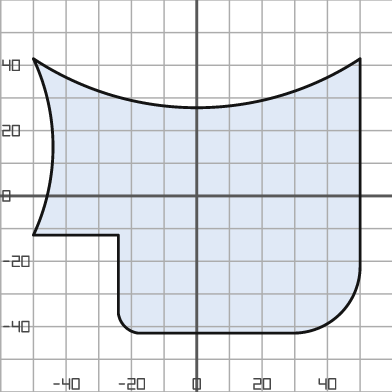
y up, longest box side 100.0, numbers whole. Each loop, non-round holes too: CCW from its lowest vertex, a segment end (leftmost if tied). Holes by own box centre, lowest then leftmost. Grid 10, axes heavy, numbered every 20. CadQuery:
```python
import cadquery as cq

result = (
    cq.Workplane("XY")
    .moveTo(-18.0, -42.0)
    .lineTo(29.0, -42.0)
    .threePointArc((44.0, -36.0), (50.0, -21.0))
    .lineTo(50.0, 42.0)
    .threePointArc((0.0, 27.0), (-50.0, 42.0))
    .threePointArc((-44.0, 15.0), (-50.0, -12.0))
    .lineTo(-24.0, -12.0)
    .lineTo(-24.0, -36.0)
    .threePointArc((-22.0, -40.0), (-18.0, -42.0))
    .close()
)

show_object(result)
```